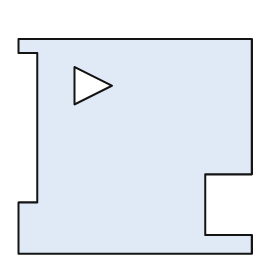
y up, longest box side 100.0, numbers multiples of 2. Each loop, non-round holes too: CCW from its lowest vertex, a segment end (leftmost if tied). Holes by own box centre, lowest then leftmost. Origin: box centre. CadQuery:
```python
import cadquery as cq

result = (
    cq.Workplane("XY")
    .moveTo(-50.0, -46.0)
    .lineTo(50.0, -46.0)
    .lineTo(50.0, -38.0)
    .lineTo(30.0, -38.0)
    .lineTo(30.0, -12.0)
    .lineTo(50.0, -12.0)
    .lineTo(50.0, 46.0)
    .lineTo(-50.0, 46.0)
    .lineTo(-50.0, 40.0)
    .lineTo(-42.0, 40.0)
    .lineTo(-42.0, -24.0)
    .lineTo(-50.0, -24.0)
    .close()
    .moveTo(-26.0, 18.0)
    .lineTo(-10.0, 26.0)
    .lineTo(-26.0, 34.0)
    .close()
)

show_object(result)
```